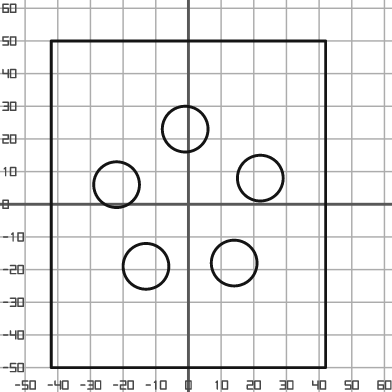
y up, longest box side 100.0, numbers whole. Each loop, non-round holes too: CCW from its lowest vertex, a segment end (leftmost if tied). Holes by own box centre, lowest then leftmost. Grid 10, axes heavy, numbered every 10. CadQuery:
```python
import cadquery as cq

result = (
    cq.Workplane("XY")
    .moveTo(-42.0, -50.0)
    .lineTo(42.0, -50.0)
    .lineTo(42.0, 50.0)
    .lineTo(-42.0, 50.0)
    .close()
    .moveTo(-13.0, -19.0)
    .circle(7.0)
    .moveTo(14.0, -18.0)
    .circle(7.0)
    .moveTo(-22.0, 6.0)
    .circle(7.0)
    .moveTo(22.0, 8.0)
    .circle(7.0)
    .moveTo(-1.0, 23.0)
    .circle(7.0)
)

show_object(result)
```